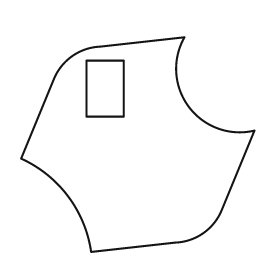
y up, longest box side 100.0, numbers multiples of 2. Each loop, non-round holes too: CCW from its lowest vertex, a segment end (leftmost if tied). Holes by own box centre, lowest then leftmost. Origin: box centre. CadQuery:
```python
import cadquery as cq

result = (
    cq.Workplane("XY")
    .moveTo(-20.0, -46.0)
    .lineTo(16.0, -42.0)
    .threePointArc((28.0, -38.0), (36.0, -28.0))
    .lineTo(50.0, 6.0)
    .threePointArc((22.0, 16.0), (20.0, 46.0))
    .lineTo(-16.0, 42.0)
    .threePointArc((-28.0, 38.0), (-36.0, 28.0))
    .lineTo(-50.0, -6.0)
    .threePointArc((-30.0, -22.0), (-20.0, -46.0))
    .close()
    .moveTo(-22.0, 12.0)
    .lineTo(-6.0, 12.0)
    .lineTo(-6.0, 36.0)
    .lineTo(-22.0, 36.0)
    .close()
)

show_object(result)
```